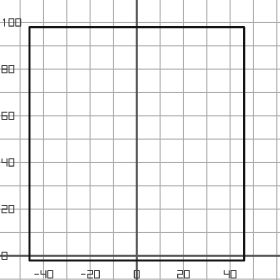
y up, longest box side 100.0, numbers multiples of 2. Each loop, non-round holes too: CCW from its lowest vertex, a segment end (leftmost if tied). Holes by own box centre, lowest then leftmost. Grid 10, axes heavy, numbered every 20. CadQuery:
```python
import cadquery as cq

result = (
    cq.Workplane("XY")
    .moveTo(-46.0, -2.0)
    .lineTo(46.0, -2.0)
    .lineTo(46.0, 98.0)
    .lineTo(-46.0, 98.0)
    .close()
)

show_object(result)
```